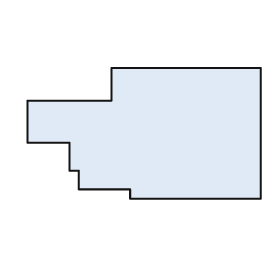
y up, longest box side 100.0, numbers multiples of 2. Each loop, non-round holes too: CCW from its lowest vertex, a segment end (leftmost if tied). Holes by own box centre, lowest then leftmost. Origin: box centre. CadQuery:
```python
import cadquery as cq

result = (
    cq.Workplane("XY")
    .moveTo(-6.0, -28.0)
    .lineTo(50.0, -28.0)
    .lineTo(50.0, 28.0)
    .lineTo(-14.0, 28.0)
    .lineTo(-14.0, 14.0)
    .lineTo(-50.0, 14.0)
    .lineTo(-50.0, -4.0)
    .lineTo(-32.0, -4.0)
    .lineTo(-32.0, -16.0)
    .lineTo(-28.0, -16.0)
    .lineTo(-28.0, -24.0)
    .lineTo(-6.0, -24.0)
    .close()
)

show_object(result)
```